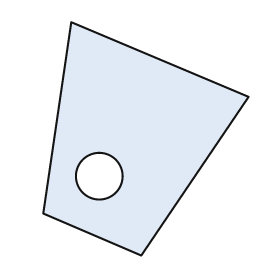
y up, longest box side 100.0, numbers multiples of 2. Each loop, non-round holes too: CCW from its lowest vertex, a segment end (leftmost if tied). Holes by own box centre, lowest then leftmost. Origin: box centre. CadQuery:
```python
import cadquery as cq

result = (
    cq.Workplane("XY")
    .moveTo(-2.0, -50.0)
    .lineTo(44.0, 18.0)
    .lineTo(-32.0, 50.0)
    .lineTo(-44.0, -32.0)
    .close()
    .moveTo(-20.0, -16.0)
    .circle(10.0)
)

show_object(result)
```